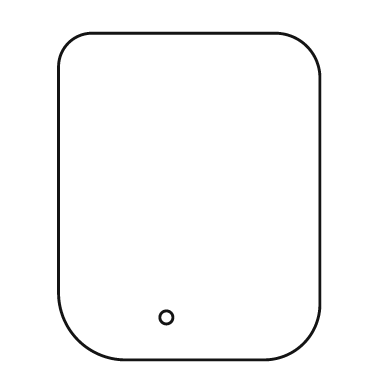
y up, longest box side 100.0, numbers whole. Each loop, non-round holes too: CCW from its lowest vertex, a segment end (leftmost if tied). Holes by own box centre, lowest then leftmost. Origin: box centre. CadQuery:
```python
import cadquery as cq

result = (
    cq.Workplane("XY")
    .moveTo(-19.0, -50.0)
    .lineTo(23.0, -50.0)
    .threePointArc((35.0, -45.0), (40.0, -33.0))
    .lineTo(40.0, 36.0)
    .threePointArc((36.0, 46.0), (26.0, 50.0))
    .lineTo(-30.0, 50.0)
    .threePointArc((-37.0, 47.0), (-40.0, 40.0))
    .lineTo(-40.0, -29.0)
    .threePointArc((-34.0, -44.0), (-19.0, -50.0))
    .close()
    .moveTo(-7.0, -37.0)
    .circle(2.0)
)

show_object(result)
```